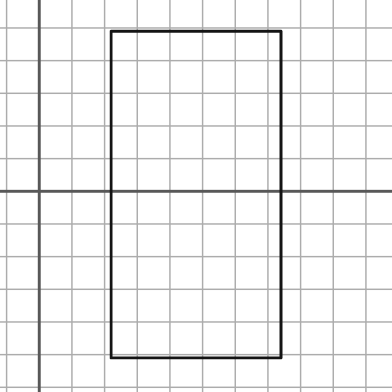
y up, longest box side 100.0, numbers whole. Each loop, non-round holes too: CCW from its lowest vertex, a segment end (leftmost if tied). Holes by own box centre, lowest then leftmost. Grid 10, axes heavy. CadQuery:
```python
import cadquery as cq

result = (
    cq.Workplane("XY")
    .moveTo(22.0, -51.0)
    .lineTo(74.0, -51.0)
    .lineTo(74.0, 49.0)
    .lineTo(22.0, 49.0)
    .close()
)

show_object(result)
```